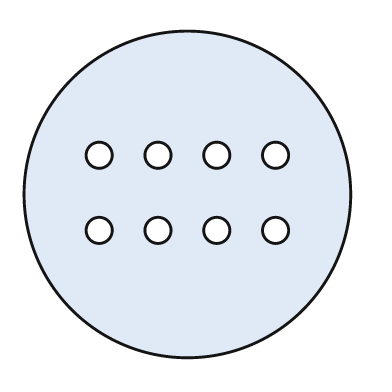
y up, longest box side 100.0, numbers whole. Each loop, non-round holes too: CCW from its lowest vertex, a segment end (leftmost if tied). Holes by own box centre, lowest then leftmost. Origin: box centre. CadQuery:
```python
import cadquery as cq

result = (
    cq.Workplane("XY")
    .moveTo(0.0, 0.0)
    .circle(50.0)
    .moveTo(-27.0, -11.0)
    .circle(4.0)
    .moveTo(-9.0, -11.0)
    .circle(4.0)
    .moveTo(9.0, -11.0)
    .circle(4.0)
    .moveTo(27.0, -11.0)
    .circle(4.0)
    .moveTo(-27.0, 12.0)
    .circle(4.0)
    .moveTo(-9.0, 12.0)
    .circle(4.0)
    .moveTo(9.0, 12.0)
    .circle(4.0)
    .moveTo(27.0, 12.0)
    .circle(4.0)
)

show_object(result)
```